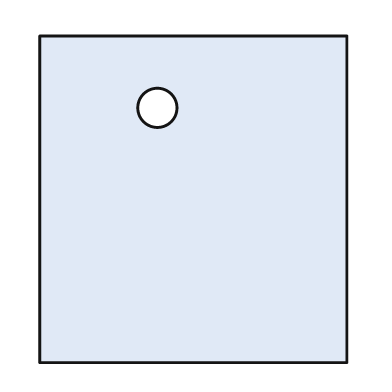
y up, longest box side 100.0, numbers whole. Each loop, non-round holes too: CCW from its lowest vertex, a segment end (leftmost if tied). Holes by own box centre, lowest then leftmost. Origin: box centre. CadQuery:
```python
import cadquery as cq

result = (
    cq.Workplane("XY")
    .moveTo(-47.0, -50.0)
    .lineTo(47.0, -50.0)
    .lineTo(47.0, 50.0)
    .lineTo(-47.0, 50.0)
    .close()
    .moveTo(-11.0, 28.0)
    .circle(6.0)
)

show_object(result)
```